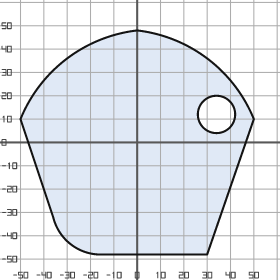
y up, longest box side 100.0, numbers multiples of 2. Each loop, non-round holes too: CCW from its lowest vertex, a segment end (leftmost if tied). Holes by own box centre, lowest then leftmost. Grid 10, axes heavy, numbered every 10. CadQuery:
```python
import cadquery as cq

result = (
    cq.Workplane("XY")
    .moveTo(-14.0, -48.0)
    .lineTo(30.0, -48.0)
    .lineTo(50.0, 10.0)
    .threePointArc((30.0, 36.0), (0.0, 48.0))
    .threePointArc((-30.0, 36.0), (-50.0, 10.0))
    .lineTo(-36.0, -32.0)
    .threePointArc((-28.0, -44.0), (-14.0, -48.0))
    .close()
    .moveTo(34.0, 12.0)
    .circle(8.0)
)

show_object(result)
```